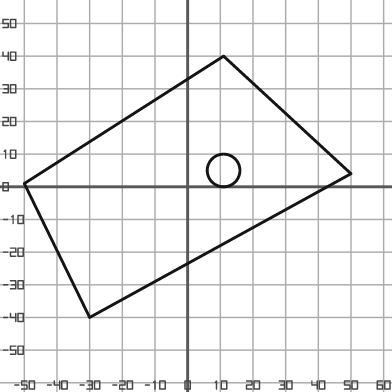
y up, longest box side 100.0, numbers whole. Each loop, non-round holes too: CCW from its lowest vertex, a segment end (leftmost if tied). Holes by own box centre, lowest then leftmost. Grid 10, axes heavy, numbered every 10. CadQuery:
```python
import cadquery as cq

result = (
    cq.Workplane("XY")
    .moveTo(-30.0, -40.0)
    .lineTo(50.0, 4.0)
    .lineTo(11.0, 40.0)
    .lineTo(-50.0, 1.0)
    .close()
    .moveTo(11.0, 5.0)
    .circle(5.0)
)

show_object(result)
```